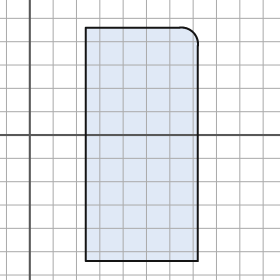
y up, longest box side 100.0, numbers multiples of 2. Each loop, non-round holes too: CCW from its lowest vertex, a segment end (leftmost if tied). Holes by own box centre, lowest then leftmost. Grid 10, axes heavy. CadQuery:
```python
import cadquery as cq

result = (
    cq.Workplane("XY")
    .moveTo(24.0, -54.0)
    .lineTo(72.0, -54.0)
    .lineTo(72.0, 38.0)
    .threePointArc((70.0, 44.0), (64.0, 46.0))
    .lineTo(24.0, 46.0)
    .close()
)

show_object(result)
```